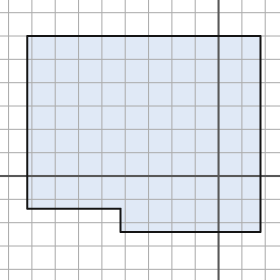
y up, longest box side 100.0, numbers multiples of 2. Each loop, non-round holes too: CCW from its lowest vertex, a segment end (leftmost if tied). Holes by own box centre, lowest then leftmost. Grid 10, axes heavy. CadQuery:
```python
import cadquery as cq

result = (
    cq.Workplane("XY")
    .moveTo(-42.0, -24.0)
    .lineTo(18.0, -24.0)
    .lineTo(18.0, 60.0)
    .lineTo(-82.0, 60.0)
    .lineTo(-82.0, -14.0)
    .lineTo(-42.0, -14.0)
    .close()
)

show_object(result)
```